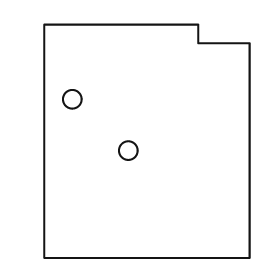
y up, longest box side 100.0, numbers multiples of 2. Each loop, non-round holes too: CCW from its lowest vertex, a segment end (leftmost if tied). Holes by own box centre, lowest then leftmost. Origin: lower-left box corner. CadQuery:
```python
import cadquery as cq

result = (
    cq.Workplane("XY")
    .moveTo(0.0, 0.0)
    .lineTo(88.0, 0.0)
    .lineTo(88.0, 92.0)
    .lineTo(66.0, 92.0)
    .lineTo(66.0, 100.0)
    .lineTo(0.0, 100.0)
    .close()
    .moveTo(36.0, 46.0)
    .circle(4.0)
    .moveTo(12.0, 68.0)
    .circle(4.0)
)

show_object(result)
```